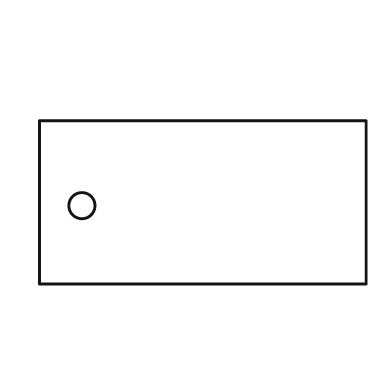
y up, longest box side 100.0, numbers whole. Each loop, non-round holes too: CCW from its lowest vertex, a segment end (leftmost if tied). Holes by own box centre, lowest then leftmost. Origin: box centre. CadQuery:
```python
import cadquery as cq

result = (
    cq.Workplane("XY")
    .moveTo(-50.0, -25.0)
    .lineTo(50.0, -25.0)
    .lineTo(50.0, 25.0)
    .lineTo(-50.0, 25.0)
    .close()
    .moveTo(-37.0, -1.0)
    .circle(4.0)
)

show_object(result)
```